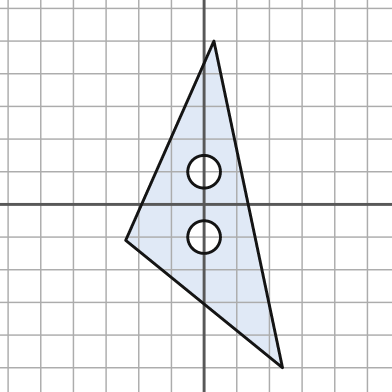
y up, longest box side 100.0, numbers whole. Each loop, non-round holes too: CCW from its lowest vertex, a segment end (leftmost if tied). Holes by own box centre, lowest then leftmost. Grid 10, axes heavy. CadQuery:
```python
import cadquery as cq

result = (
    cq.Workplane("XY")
    .moveTo(24.0, -50.0)
    .lineTo(3.0, 50.0)
    .lineTo(-24.0, -11.0)
    .close()
    .moveTo(0.0, -10.0)
    .circle(5.0)
    .moveTo(0.0, 10.0)
    .circle(5.0)
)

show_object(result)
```